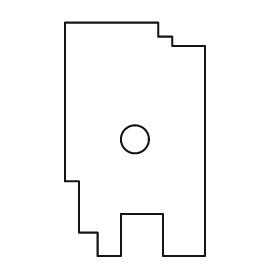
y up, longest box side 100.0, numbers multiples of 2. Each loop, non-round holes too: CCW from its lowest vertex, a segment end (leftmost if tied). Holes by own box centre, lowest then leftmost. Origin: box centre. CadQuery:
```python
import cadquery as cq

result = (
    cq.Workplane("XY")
    .moveTo(-16.0, -50.0)
    .lineTo(-6.0, -50.0)
    .lineTo(-6.0, -32.0)
    .lineTo(12.0, -32.0)
    .lineTo(12.0, -50.0)
    .lineTo(30.0, -50.0)
    .lineTo(30.0, 40.0)
    .lineTo(16.0, 40.0)
    .lineTo(16.0, 44.0)
    .lineTo(10.0, 44.0)
    .lineTo(10.0, 50.0)
    .lineTo(-30.0, 50.0)
    .lineTo(-30.0, -18.0)
    .lineTo(-24.0, -18.0)
    .lineTo(-24.0, -40.0)
    .lineTo(-16.0, -40.0)
    .close()
    .moveTo(0.0, 0.0)
    .circle(6.0)
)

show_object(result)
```